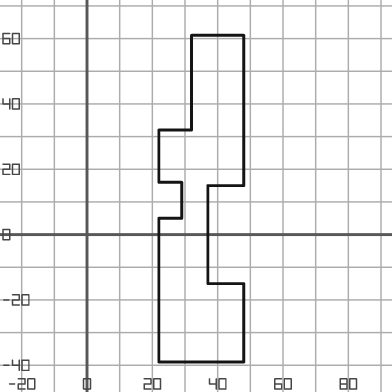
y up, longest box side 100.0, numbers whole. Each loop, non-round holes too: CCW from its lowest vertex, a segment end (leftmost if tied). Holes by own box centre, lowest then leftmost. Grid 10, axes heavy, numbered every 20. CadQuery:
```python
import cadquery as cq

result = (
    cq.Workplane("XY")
    .moveTo(22.0, -39.0)
    .lineTo(48.0, -39.0)
    .lineTo(48.0, -15.0)
    .lineTo(37.0, -15.0)
    .lineTo(37.0, 15.0)
    .lineTo(48.0, 15.0)
    .lineTo(48.0, 61.0)
    .lineTo(32.0, 61.0)
    .lineTo(32.0, 32.0)
    .lineTo(22.0, 32.0)
    .lineTo(22.0, 16.0)
    .lineTo(29.0, 16.0)
    .lineTo(29.0, 5.0)
    .lineTo(22.0, 5.0)
    .close()
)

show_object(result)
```